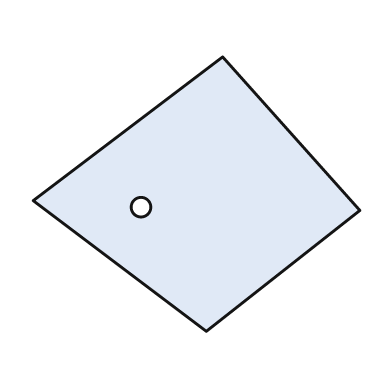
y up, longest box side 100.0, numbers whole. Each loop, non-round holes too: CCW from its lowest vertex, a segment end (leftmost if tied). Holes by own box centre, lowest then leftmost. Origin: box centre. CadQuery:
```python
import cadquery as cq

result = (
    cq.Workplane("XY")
    .moveTo(3.0, -42.0)
    .lineTo(50.0, -5.0)
    .lineTo(8.0, 42.0)
    .lineTo(-50.0, -2.0)
    .close()
    .moveTo(-17.0, -4.0)
    .circle(3.0)
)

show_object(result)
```